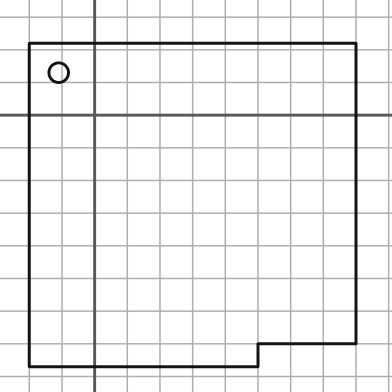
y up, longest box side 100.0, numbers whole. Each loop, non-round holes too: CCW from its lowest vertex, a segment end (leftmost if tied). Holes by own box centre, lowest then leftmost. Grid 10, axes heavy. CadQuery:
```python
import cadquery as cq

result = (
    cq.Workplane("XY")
    .moveTo(-20.0, -77.0)
    .lineTo(50.0, -77.0)
    .lineTo(50.0, -70.0)
    .lineTo(80.0, -70.0)
    .lineTo(80.0, 22.0)
    .lineTo(-20.0, 22.0)
    .close()
    .moveTo(-11.0, 13.0)
    .circle(3.0)
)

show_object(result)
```